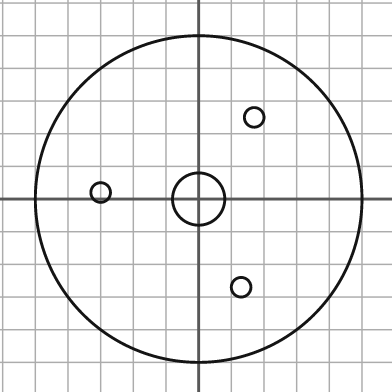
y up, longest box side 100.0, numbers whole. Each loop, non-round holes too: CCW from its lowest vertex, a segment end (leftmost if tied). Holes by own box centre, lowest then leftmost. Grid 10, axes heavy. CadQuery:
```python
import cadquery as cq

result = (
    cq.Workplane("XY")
    .moveTo(0.0, 0.0)
    .circle(50.0)
    .moveTo(13.0, -27.0)
    .circle(3.0)
    .moveTo(0.0, 0.0)
    .circle(8.0)
    .moveTo(-30.0, 2.0)
    .circle(3.0)
    .moveTo(17.0, 25.0)
    .circle(3.0)
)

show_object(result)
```